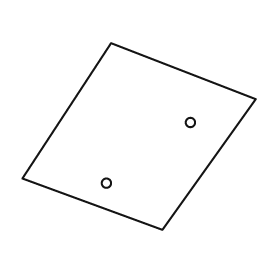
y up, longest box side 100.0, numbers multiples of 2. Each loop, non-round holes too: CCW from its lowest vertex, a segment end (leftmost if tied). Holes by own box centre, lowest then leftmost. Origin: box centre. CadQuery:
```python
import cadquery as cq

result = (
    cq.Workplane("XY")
    .moveTo(10.0, -40.0)
    .lineTo(50.0, 16.0)
    .lineTo(-12.0, 40.0)
    .lineTo(-50.0, -18.0)
    .close()
    .moveTo(-14.0, -20.0)
    .circle(2.0)
    .moveTo(22.0, 6.0)
    .circle(2.0)
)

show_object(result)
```